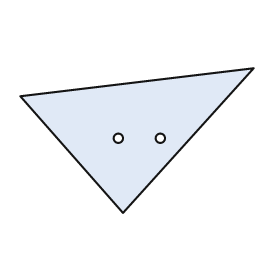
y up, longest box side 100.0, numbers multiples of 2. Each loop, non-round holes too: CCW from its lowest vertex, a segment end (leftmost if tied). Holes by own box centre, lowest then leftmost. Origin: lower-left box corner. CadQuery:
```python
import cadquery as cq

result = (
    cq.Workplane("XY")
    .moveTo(44.0, 0.0)
    .lineTo(100.0, 62.0)
    .lineTo(0.0, 50.0)
    .close()
    .moveTo(42.0, 32.0)
    .circle(2.0)
    .moveTo(60.0, 32.0)
    .circle(2.0)
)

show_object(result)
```